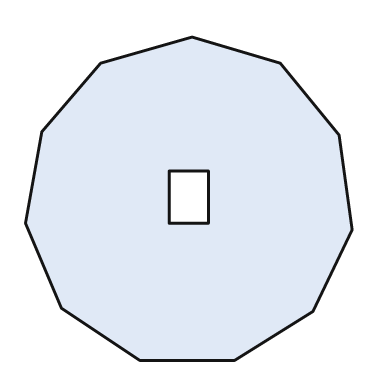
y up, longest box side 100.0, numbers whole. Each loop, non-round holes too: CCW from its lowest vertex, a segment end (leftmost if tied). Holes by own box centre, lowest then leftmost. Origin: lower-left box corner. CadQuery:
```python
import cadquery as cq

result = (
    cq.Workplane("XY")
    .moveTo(35.0, 0.0)
    .lineTo(64.0, 0.0)
    .lineTo(88.0, 15.0)
    .lineTo(100.0, 40.0)
    .lineTo(96.0, 69.0)
    .lineTo(78.0, 91.0)
    .lineTo(51.0, 99.0)
    .lineTo(23.0, 91.0)
    .lineTo(5.0, 70.0)
    .lineTo(0.0, 42.0)
    .lineTo(11.0, 16.0)
    .close()
    .moveTo(44.0, 42.0)
    .lineTo(56.0, 42.0)
    .lineTo(56.0, 58.0)
    .lineTo(44.0, 58.0)
    .close()
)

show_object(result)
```